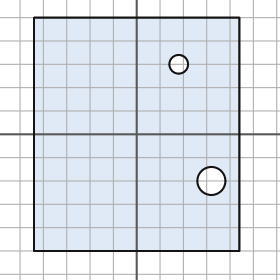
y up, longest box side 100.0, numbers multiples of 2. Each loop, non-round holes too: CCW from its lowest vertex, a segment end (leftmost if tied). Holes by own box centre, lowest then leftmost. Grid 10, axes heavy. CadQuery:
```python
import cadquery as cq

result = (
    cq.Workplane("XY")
    .moveTo(-44.0, -50.0)
    .lineTo(44.0, -50.0)
    .lineTo(44.0, 50.0)
    .lineTo(-44.0, 50.0)
    .close()
    .moveTo(32.0, -20.0)
    .circle(6.0)
    .moveTo(18.0, 30.0)
    .circle(4.0)
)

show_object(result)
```